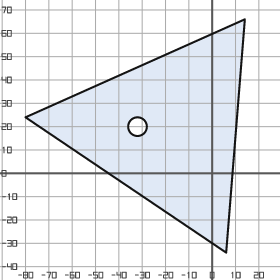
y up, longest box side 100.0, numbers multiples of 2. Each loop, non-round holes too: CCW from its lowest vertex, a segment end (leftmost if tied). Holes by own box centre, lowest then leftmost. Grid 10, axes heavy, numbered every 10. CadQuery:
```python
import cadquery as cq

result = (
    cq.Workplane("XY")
    .moveTo(6.0, -34.0)
    .lineTo(14.0, 66.0)
    .lineTo(-80.0, 24.0)
    .close()
    .moveTo(-32.0, 20.0)
    .circle(4.0)
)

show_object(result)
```